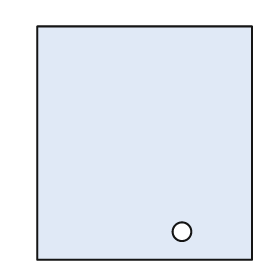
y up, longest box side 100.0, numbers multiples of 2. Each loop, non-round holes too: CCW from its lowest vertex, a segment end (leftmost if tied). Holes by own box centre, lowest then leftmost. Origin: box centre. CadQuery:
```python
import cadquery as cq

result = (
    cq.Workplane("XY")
    .moveTo(-46.0, -50.0)
    .lineTo(46.0, -50.0)
    .lineTo(46.0, 50.0)
    .lineTo(-46.0, 50.0)
    .close()
    .moveTo(16.0, -38.0)
    .circle(4.0)
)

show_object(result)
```